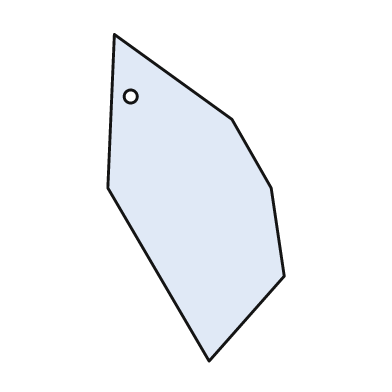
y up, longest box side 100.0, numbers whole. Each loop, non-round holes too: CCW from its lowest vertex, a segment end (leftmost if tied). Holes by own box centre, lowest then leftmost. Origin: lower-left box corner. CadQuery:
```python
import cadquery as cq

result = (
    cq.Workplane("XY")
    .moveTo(31.0, 0.0)
    .lineTo(54.0, 26.0)
    .lineTo(50.0, 53.0)
    .lineTo(38.0, 74.0)
    .lineTo(2.0, 100.0)
    .lineTo(0.0, 53.0)
    .close()
    .moveTo(7.0, 81.0)
    .circle(2.0)
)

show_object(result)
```